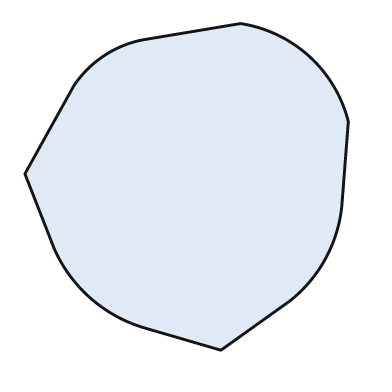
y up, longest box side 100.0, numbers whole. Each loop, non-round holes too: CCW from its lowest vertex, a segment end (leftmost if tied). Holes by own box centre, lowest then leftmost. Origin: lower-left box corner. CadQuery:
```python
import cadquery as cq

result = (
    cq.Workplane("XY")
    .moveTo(60.0, 0.0)
    .lineTo(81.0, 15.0)
    .threePointArc((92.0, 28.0), (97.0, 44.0))
    .lineTo(99.0, 70.0)
    .threePointArc((87.0, 90.0), (66.0, 100.0))
    .lineTo(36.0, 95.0)
    .threePointArc((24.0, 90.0), (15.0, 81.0))
    .lineTo(0.0, 54.0)
    .lineTo(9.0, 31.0)
    .threePointArc((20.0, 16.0), (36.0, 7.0))
    .close()
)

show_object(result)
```